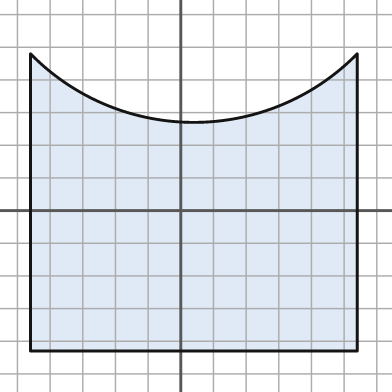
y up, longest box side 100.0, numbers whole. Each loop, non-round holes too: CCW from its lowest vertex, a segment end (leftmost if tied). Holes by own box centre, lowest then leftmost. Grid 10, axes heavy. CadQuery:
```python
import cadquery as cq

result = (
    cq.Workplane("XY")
    .moveTo(-46.0, -43.0)
    .lineTo(54.0, -43.0)
    .lineTo(54.0, 48.0)
    .threePointArc((4.0, 27.0), (-46.0, 48.0))
    .close()
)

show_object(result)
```